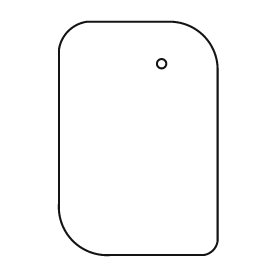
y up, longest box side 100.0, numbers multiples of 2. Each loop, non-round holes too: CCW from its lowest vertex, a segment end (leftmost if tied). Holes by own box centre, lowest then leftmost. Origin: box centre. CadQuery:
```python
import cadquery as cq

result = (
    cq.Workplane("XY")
    .moveTo(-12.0, -50.0)
    .lineTo(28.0, -50.0)
    .threePointArc((32.0, -48.0), (34.0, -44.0))
    .lineTo(34.0, 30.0)
    .threePointArc((28.0, 44.0), (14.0, 50.0))
    .lineTo(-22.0, 50.0)
    .threePointArc((-30.0, 46.0), (-34.0, 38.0))
    .lineTo(-34.0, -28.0)
    .threePointArc((-28.0, -44.0), (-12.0, -50.0))
    .close()
    .moveTo(10.0, 32.0)
    .circle(2.0)
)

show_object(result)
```